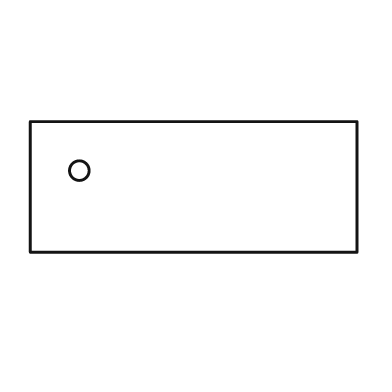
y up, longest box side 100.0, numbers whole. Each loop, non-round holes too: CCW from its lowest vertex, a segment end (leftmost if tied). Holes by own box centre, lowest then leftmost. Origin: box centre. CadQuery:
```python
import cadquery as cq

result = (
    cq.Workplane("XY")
    .moveTo(-50.0, -20.0)
    .lineTo(50.0, -20.0)
    .lineTo(50.0, 20.0)
    .lineTo(-50.0, 20.0)
    .close()
    .moveTo(-35.0, 5.0)
    .circle(3.0)
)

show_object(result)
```